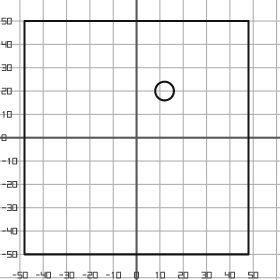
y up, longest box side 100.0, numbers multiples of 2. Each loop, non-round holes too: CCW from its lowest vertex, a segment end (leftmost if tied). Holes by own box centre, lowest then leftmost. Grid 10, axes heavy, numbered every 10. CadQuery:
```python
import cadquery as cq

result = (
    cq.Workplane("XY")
    .moveTo(-48.0, -50.0)
    .lineTo(48.0, -50.0)
    .lineTo(48.0, 50.0)
    .lineTo(-48.0, 50.0)
    .close()
    .moveTo(12.0, 20.0)
    .circle(4.0)
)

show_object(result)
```